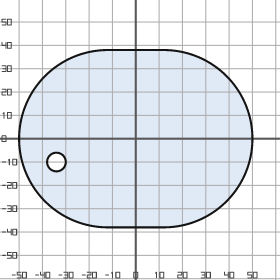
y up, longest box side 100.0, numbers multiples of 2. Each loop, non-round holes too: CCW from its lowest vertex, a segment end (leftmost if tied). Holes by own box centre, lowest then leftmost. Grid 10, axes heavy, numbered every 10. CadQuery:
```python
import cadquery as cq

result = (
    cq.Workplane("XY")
    .moveTo(-12.0, -38.0)
    .lineTo(12.0, -38.0)
    .threePointArc((50.0, 0.0), (12.0, 38.0))
    .lineTo(-12.0, 38.0)
    .threePointArc((-50.0, 0.0), (-12.0, -38.0))
    .close()
    .moveTo(-34.0, -10.0)
    .circle(4.0)
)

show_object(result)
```